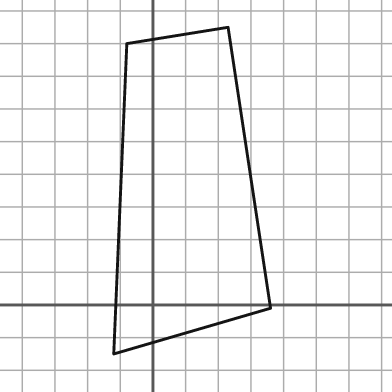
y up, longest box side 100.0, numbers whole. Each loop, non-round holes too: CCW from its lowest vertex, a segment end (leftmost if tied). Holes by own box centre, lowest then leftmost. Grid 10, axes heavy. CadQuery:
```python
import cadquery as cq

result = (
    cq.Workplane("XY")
    .moveTo(-12.0, -15.0)
    .lineTo(36.0, -1.0)
    .lineTo(23.0, 85.0)
    .lineTo(-8.0, 80.0)
    .close()
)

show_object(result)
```